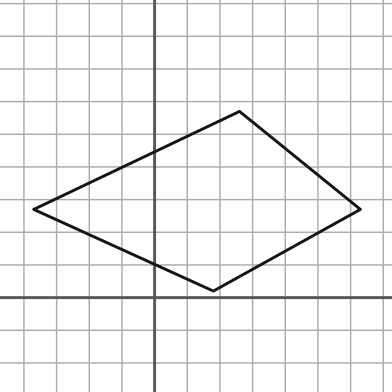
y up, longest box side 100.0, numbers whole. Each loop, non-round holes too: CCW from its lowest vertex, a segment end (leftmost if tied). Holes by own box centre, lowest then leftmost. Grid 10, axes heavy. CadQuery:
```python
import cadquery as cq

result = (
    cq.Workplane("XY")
    .moveTo(18.0, 2.0)
    .lineTo(63.0, 27.0)
    .lineTo(26.0, 57.0)
    .lineTo(-37.0, 27.0)
    .close()
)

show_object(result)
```